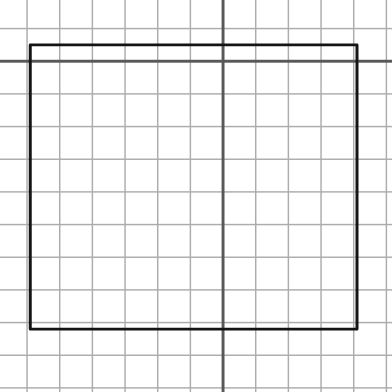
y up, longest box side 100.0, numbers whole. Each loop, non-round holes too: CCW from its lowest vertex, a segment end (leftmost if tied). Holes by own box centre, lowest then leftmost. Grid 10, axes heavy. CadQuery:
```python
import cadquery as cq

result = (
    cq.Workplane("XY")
    .moveTo(-59.0, -82.0)
    .lineTo(41.0, -82.0)
    .lineTo(41.0, 5.0)
    .lineTo(-59.0, 5.0)
    .close()
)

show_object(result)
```